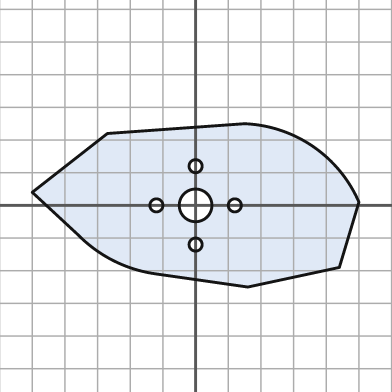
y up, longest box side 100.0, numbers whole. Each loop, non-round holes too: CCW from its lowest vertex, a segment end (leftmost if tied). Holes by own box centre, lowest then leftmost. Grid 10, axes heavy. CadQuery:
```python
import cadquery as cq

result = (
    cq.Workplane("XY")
    .moveTo(16.0, -25.0)
    .lineTo(44.0, -19.0)
    .lineTo(50.0, 1.0)
    .threePointArc((36.0, 18.0), (15.0, 25.0))
    .lineTo(-27.0, 22.0)
    .lineTo(-50.0, 4.0)
    .lineTo(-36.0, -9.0)
    .threePointArc((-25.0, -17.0), (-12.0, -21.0))
    .close()
    .moveTo(0.0, -12.0)
    .circle(2.0)
    .moveTo(-12.0, 0.0)
    .circle(2.0)
    .moveTo(0.0, 0.0)
    .circle(5.0)
    .moveTo(12.0, 0.0)
    .circle(2.0)
    .moveTo(0.0, 12.0)
    .circle(2.0)
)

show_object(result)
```